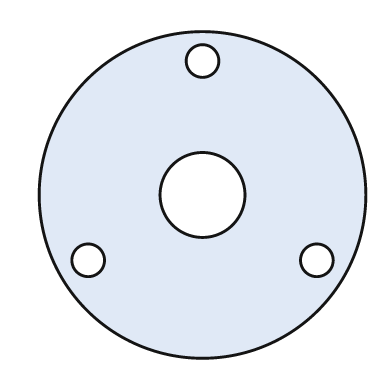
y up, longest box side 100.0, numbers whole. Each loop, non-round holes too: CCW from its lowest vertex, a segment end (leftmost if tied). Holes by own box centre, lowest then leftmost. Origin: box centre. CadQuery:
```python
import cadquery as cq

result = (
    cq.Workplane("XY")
    .moveTo(0.0, 0.0)
    .circle(50.0)
    .moveTo(-35.0, -20.0)
    .circle(5.0)
    .moveTo(35.0, -20.0)
    .circle(5.0)
    .moveTo(0.0, 0.0)
    .circle(13.0)
    .moveTo(0.0, 41.0)
    .circle(5.0)
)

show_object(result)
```